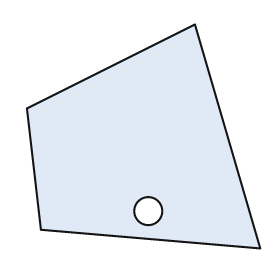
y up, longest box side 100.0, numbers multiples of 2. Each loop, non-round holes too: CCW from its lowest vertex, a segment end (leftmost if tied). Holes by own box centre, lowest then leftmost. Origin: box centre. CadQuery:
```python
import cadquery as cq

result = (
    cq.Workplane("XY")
    .moveTo(50.0, -48.0)
    .lineTo(22.0, 48.0)
    .lineTo(-50.0, 12.0)
    .lineTo(-44.0, -40.0)
    .close()
    .moveTo(2.0, -32.0)
    .circle(6.0)
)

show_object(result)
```